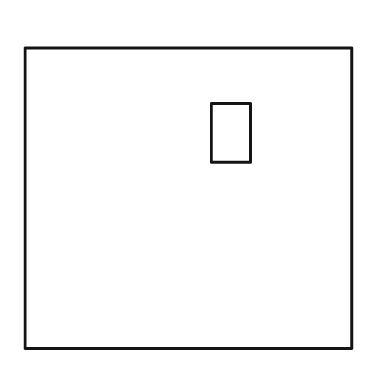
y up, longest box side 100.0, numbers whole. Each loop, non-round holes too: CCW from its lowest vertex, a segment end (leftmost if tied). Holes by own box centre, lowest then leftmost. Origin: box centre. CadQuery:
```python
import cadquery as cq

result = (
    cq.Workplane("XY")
    .moveTo(-50.0, -46.0)
    .lineTo(50.0, -46.0)
    .lineTo(50.0, 46.0)
    .lineTo(-50.0, 46.0)
    .close()
    .moveTo(7.0, 11.0)
    .lineTo(19.0, 11.0)
    .lineTo(19.0, 29.0)
    .lineTo(7.0, 29.0)
    .close()
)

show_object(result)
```